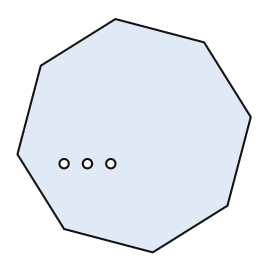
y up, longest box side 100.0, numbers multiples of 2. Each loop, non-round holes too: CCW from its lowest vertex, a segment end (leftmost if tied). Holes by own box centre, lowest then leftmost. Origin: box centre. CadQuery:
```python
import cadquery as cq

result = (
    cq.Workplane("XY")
    .moveTo(8.0, -50.0)
    .lineTo(40.0, -30.0)
    .lineTo(50.0, 8.0)
    .lineTo(30.0, 40.0)
    .lineTo(-8.0, 50.0)
    .lineTo(-40.0, 30.0)
    .lineTo(-50.0, -8.0)
    .lineTo(-30.0, -40.0)
    .close()
    .moveTo(-30.0, -12.0)
    .circle(2.0)
    .moveTo(-20.0, -12.0)
    .circle(2.0)
    .moveTo(-10.0, -12.0)
    .circle(2.0)
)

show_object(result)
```